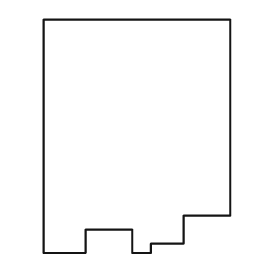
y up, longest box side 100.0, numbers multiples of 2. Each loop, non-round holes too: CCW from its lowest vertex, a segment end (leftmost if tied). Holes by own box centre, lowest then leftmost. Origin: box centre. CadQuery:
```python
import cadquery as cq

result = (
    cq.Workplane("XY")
    .moveTo(-40.0, -50.0)
    .lineTo(-22.0, -50.0)
    .lineTo(-22.0, -40.0)
    .lineTo(-2.0, -40.0)
    .lineTo(-2.0, -50.0)
    .lineTo(6.0, -50.0)
    .lineTo(6.0, -46.0)
    .lineTo(20.0, -46.0)
    .lineTo(20.0, -34.0)
    .lineTo(40.0, -34.0)
    .lineTo(40.0, 50.0)
    .lineTo(-40.0, 50.0)
    .close()
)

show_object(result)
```